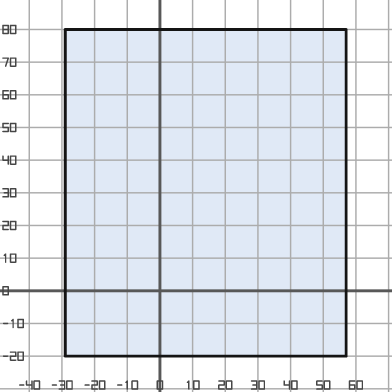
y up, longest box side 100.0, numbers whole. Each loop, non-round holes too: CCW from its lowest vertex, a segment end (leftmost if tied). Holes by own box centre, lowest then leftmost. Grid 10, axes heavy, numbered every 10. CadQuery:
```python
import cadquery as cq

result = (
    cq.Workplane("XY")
    .moveTo(-29.0, -20.0)
    .lineTo(57.0, -20.0)
    .lineTo(57.0, 80.0)
    .lineTo(-29.0, 80.0)
    .close()
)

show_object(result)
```